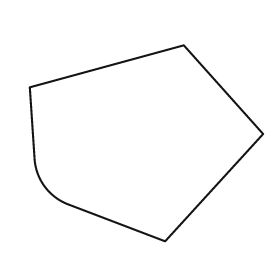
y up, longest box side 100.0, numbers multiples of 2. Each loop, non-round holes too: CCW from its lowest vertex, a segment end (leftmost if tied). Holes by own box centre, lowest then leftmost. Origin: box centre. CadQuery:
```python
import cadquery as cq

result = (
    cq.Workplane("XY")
    .moveTo(8.0, -42.0)
    .lineTo(50.0, 4.0)
    .lineTo(16.0, 42.0)
    .lineTo(-50.0, 24.0)
    .lineTo(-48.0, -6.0)
    .threePointArc((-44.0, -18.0), (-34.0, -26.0))
    .close()
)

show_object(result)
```